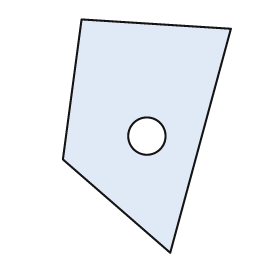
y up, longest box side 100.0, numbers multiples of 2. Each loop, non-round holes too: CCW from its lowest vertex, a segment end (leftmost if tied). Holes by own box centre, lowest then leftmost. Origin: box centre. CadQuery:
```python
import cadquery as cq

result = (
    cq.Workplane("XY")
    .moveTo(10.0, -50.0)
    .lineTo(36.0, 46.0)
    .lineTo(-28.0, 50.0)
    .lineTo(-36.0, -10.0)
    .close()
    .moveTo(0.0, 0.0)
    .circle(8.0)
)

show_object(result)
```